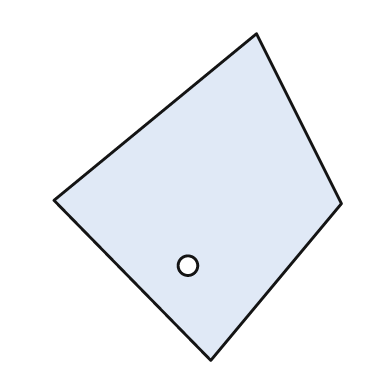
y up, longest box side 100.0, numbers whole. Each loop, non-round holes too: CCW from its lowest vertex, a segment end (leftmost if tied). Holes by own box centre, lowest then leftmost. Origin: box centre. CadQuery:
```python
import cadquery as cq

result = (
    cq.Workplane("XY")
    .moveTo(4.0, -50.0)
    .lineTo(44.0, -2.0)
    .lineTo(18.0, 50.0)
    .lineTo(-44.0, -1.0)
    .close()
    .moveTo(-3.0, -21.0)
    .circle(3.0)
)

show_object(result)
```